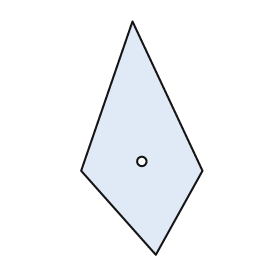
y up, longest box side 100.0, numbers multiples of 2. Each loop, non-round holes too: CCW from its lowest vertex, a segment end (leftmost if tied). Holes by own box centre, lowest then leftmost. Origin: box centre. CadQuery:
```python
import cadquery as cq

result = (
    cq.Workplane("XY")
    .moveTo(6.0, -50.0)
    .lineTo(26.0, -14.0)
    .lineTo(-4.0, 50.0)
    .lineTo(-26.0, -14.0)
    .close()
    .moveTo(0.0, -10.0)
    .circle(2.0)
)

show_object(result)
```